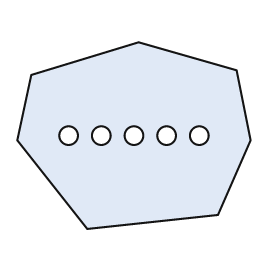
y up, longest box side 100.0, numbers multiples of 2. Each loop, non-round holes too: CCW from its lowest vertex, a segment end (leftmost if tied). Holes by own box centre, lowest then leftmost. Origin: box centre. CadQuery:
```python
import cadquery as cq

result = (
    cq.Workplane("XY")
    .moveTo(-20.0, -40.0)
    .lineTo(36.0, -34.0)
    .lineTo(50.0, -2.0)
    .lineTo(44.0, 28.0)
    .lineTo(2.0, 40.0)
    .lineTo(-44.0, 26.0)
    .lineTo(-50.0, -2.0)
    .close()
    .moveTo(-28.0, 0.0)
    .circle(4.0)
    .moveTo(-14.0, 0.0)
    .circle(4.0)
    .moveTo(0.0, 0.0)
    .circle(4.0)
    .moveTo(14.0, 0.0)
    .circle(4.0)
    .moveTo(28.0, 0.0)
    .circle(4.0)
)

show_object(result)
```